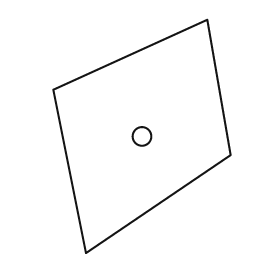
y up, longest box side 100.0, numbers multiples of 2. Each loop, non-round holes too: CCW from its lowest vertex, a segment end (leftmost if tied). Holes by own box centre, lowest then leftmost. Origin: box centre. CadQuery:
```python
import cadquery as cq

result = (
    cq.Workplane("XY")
    .moveTo(-24.0, -50.0)
    .lineTo(38.0, -8.0)
    .lineTo(28.0, 50.0)
    .lineTo(-38.0, 20.0)
    .close()
    .moveTo(0.0, 0.0)
    .circle(4.0)
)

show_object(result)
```